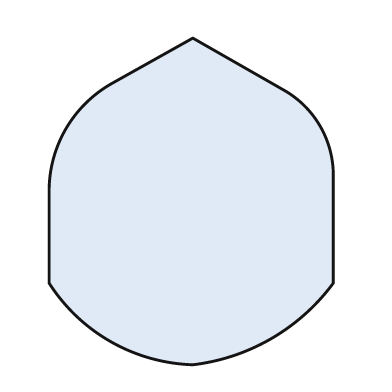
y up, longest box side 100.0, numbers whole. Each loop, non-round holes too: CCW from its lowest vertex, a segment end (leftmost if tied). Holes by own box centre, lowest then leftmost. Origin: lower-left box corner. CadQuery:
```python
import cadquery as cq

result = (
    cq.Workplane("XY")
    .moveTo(44.0, 0.0)
    .threePointArc((68.0, 8.0), (87.0, 25.0))
    .lineTo(87.0, 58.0)
    .threePointArc((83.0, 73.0), (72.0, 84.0))
    .lineTo(44.0, 100.0)
    .lineTo(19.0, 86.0)
    .threePointArc((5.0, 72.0), (0.0, 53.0))
    .lineTo(0.0, 25.0)
    .threePointArc((19.0, 7.0), (44.0, 0.0))
    .close()
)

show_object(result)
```